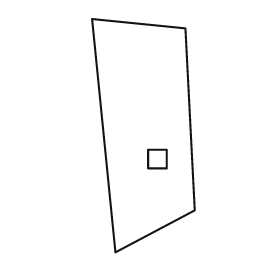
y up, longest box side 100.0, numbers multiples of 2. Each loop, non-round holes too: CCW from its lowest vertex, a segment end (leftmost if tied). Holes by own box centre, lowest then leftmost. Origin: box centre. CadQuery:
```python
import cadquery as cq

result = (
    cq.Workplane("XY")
    .moveTo(-12.0, -50.0)
    .lineTo(22.0, -32.0)
    .lineTo(18.0, 46.0)
    .lineTo(-22.0, 50.0)
    .close()
    .moveTo(2.0, -14.0)
    .lineTo(10.0, -14.0)
    .lineTo(10.0, -6.0)
    .lineTo(2.0, -6.0)
    .close()
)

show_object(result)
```